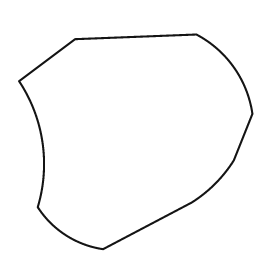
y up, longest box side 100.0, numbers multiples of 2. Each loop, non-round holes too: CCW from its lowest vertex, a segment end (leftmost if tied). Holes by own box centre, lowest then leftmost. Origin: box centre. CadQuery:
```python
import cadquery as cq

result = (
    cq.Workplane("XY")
    .moveTo(-14.0, -46.0)
    .lineTo(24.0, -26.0)
    .threePointArc((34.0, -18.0), (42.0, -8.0))
    .lineTo(50.0, 12.0)
    .threePointArc((42.0, 32.0), (26.0, 46.0))
    .lineTo(-26.0, 44.0)
    .lineTo(-50.0, 26.0)
    .threePointArc((-40.0, 0.0), (-42.0, -28.0))
    .threePointArc((-30.0, -40.0), (-14.0, -46.0))
    .close()
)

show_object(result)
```